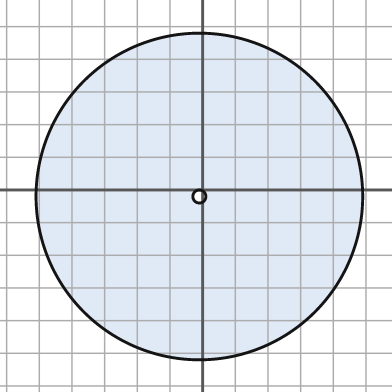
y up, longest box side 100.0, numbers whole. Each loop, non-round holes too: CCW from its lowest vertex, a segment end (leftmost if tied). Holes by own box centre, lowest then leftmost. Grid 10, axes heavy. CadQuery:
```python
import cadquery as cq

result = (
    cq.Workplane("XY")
    .moveTo(-1.0, -2.0)
    .circle(50.0)
    .moveTo(-1.0, -2.0)
    .circle(2.0)
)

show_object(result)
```